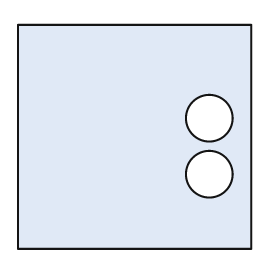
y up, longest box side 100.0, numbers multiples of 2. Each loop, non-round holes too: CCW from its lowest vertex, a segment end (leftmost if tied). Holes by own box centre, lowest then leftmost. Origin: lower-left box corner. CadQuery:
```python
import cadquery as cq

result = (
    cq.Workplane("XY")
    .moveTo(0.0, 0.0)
    .lineTo(100.0, 0.0)
    .lineTo(100.0, 96.0)
    .lineTo(0.0, 96.0)
    .close()
    .moveTo(82.0, 32.0)
    .circle(10.0)
    .moveTo(82.0, 56.0)
    .circle(10.0)
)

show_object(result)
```